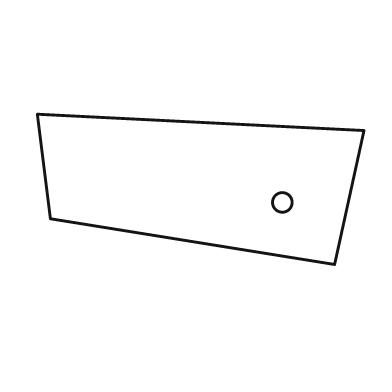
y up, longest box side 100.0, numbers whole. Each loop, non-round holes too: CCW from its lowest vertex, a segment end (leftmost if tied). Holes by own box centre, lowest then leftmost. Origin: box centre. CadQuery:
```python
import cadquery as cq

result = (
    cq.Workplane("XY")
    .moveTo(41.0, -23.0)
    .lineTo(50.0, 18.0)
    .lineTo(-50.0, 23.0)
    .lineTo(-46.0, -9.0)
    .close()
    .moveTo(25.0, -4.0)
    .circle(3.0)
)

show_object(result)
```